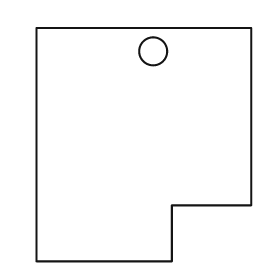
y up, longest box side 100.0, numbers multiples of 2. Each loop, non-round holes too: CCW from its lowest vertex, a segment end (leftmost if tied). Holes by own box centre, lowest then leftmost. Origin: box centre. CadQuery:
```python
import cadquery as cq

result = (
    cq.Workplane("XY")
    .moveTo(-46.0, -50.0)
    .lineTo(12.0, -50.0)
    .lineTo(12.0, -26.0)
    .lineTo(46.0, -26.0)
    .lineTo(46.0, 50.0)
    .lineTo(-46.0, 50.0)
    .close()
    .moveTo(4.0, 40.0)
    .circle(6.0)
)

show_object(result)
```